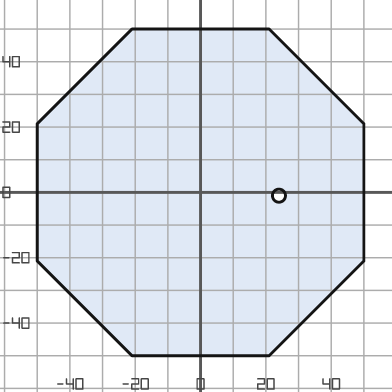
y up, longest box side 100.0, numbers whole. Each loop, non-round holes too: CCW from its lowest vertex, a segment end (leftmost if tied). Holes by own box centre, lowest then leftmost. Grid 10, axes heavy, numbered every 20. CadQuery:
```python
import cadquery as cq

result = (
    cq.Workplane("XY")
    .moveTo(-21.0, -50.0)
    .lineTo(21.0, -50.0)
    .lineTo(50.0, -21.0)
    .lineTo(50.0, 21.0)
    .lineTo(21.0, 50.0)
    .lineTo(-21.0, 50.0)
    .lineTo(-50.0, 21.0)
    .lineTo(-50.0, -21.0)
    .close()
    .moveTo(24.0, -1.0)
    .circle(2.0)
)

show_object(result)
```